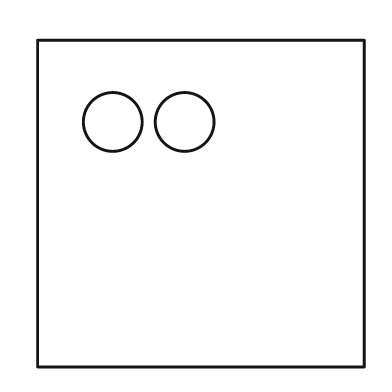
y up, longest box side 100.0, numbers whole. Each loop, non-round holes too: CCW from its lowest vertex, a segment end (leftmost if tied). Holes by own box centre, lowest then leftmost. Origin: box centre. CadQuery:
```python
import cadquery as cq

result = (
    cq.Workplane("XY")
    .moveTo(-50.0, -50.0)
    .lineTo(50.0, -50.0)
    .lineTo(50.0, 50.0)
    .lineTo(-50.0, 50.0)
    .close()
    .moveTo(-27.0, 25.0)
    .circle(9.0)
    .moveTo(-5.0, 25.0)
    .circle(9.0)
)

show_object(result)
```